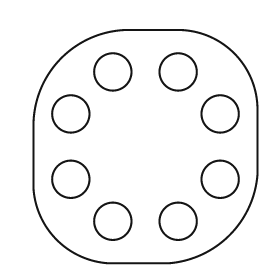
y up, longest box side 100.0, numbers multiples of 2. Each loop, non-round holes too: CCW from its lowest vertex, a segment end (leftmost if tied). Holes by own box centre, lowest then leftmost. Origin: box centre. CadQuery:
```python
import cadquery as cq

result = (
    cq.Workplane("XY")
    .moveTo(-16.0, -50.0)
    .lineTo(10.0, -50.0)
    .threePointArc((36.0, -38.0), (48.0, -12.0))
    .lineTo(48.0, 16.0)
    .threePointArc((38.0, 40.0), (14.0, 50.0))
    .lineTo(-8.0, 50.0)
    .threePointArc((-36.0, 38.0), (-48.0, 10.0))
    .lineTo(-48.0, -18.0)
    .threePointArc((-38.0, -40.0), (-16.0, -50.0))
    .close()
    .moveTo(-14.0, -32.0)
    .circle(8.0)
    .moveTo(14.0, -32.0)
    .circle(8.0)
    .moveTo(-32.0, -14.0)
    .circle(8.0)
    .moveTo(32.0, -14.0)
    .circle(8.0)
    .moveTo(-32.0, 14.0)
    .circle(8.0)
    .moveTo(32.0, 14.0)
    .circle(8.0)
    .moveTo(-14.0, 32.0)
    .circle(8.0)
    .moveTo(14.0, 32.0)
    .circle(8.0)
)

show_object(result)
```